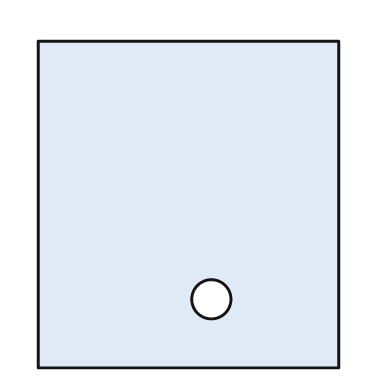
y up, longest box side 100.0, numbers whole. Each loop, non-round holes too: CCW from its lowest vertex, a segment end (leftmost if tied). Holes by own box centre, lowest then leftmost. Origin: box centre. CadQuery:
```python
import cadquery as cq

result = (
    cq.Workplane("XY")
    .moveTo(-46.0, -50.0)
    .lineTo(46.0, -50.0)
    .lineTo(46.0, 50.0)
    .lineTo(-46.0, 50.0)
    .close()
    .moveTo(7.0, -29.0)
    .circle(6.0)
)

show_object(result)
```